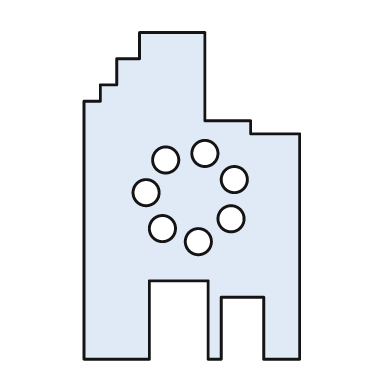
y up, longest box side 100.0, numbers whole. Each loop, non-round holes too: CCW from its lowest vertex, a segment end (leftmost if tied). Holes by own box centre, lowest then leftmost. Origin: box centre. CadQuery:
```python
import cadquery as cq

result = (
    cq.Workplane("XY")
    .moveTo(-33.0, -50.0)
    .lineTo(-13.0, -50.0)
    .lineTo(-13.0, -26.0)
    .lineTo(5.0, -26.0)
    .lineTo(5.0, -50.0)
    .lineTo(9.0, -50.0)
    .lineTo(9.0, -31.0)
    .lineTo(22.0, -31.0)
    .lineTo(22.0, -50.0)
    .lineTo(33.0, -50.0)
    .lineTo(33.0, 19.0)
    .lineTo(18.0, 19.0)
    .lineTo(18.0, 23.0)
    .lineTo(4.0, 23.0)
    .lineTo(4.0, 50.0)
    .lineTo(-16.0, 50.0)
    .lineTo(-16.0, 42.0)
    .lineTo(-23.0, 42.0)
    .lineTo(-23.0, 34.0)
    .lineTo(-28.0, 34.0)
    .lineTo(-28.0, 29.0)
    .lineTo(-33.0, 29.0)
    .close()
    .moveTo(2.0, -14.0)
    .circle(4.0)
    .moveTo(-9.0, -10.0)
    .circle(4.0)
    .moveTo(12.0, -7.0)
    .circle(4.0)
    .moveTo(-14.0, 1.0)
    .circle(4.0)
    .moveTo(13.0, 5.0)
    .circle(4.0)
    .moveTo(-8.0, 11.0)
    .circle(4.0)
    .moveTo(4.0, 13.0)
    .circle(4.0)
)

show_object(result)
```